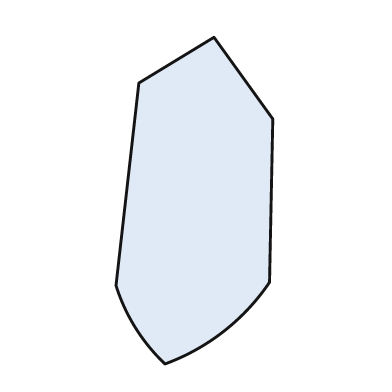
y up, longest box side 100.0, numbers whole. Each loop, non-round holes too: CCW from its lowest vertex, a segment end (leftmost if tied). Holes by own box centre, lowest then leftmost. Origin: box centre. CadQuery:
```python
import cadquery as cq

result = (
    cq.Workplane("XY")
    .moveTo(-9.0, -50.0)
    .threePointArc((9.0, -40.0), (23.0, -25.0))
    .lineTo(24.0, 25.0)
    .lineTo(6.0, 50.0)
    .lineTo(-17.0, 36.0)
    .lineTo(-24.0, -26.0)
    .threePointArc((-18.0, -39.0), (-9.0, -50.0))
    .close()
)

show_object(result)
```